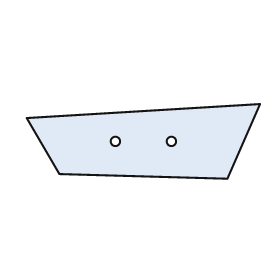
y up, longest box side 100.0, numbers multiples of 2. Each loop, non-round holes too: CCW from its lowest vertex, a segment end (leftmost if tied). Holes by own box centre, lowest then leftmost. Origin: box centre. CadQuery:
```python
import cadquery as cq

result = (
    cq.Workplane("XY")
    .moveTo(36.0, -16.0)
    .lineTo(50.0, 16.0)
    .lineTo(-50.0, 10.0)
    .lineTo(-36.0, -14.0)
    .close()
    .moveTo(-12.0, 0.0)
    .circle(2.0)
    .moveTo(12.0, 0.0)
    .circle(2.0)
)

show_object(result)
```